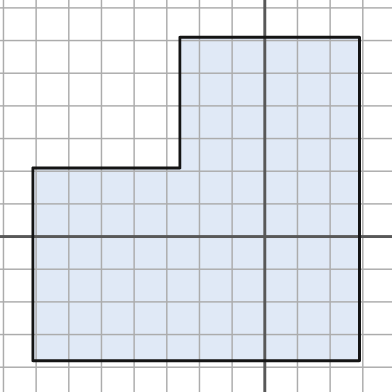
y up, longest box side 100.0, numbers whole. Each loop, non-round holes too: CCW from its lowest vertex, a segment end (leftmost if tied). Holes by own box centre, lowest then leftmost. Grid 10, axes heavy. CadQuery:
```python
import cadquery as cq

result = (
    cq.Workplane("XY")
    .moveTo(-71.0, -38.0)
    .lineTo(29.0, -38.0)
    .lineTo(29.0, 61.0)
    .lineTo(-26.0, 61.0)
    .lineTo(-26.0, 21.0)
    .lineTo(-71.0, 21.0)
    .close()
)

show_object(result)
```